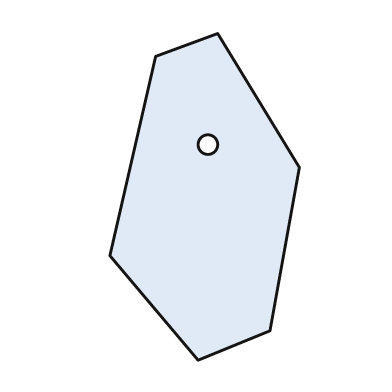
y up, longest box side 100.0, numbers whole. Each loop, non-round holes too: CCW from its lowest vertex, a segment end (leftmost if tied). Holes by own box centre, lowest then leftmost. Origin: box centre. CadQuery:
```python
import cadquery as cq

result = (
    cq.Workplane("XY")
    .moveTo(-2.0, -50.0)
    .lineTo(20.0, -41.0)
    .lineTo(29.0, 9.0)
    .lineTo(4.0, 50.0)
    .lineTo(-15.0, 43.0)
    .lineTo(-29.0, -18.0)
    .close()
    .moveTo(1.0, 16.0)
    .circle(3.0)
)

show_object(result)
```